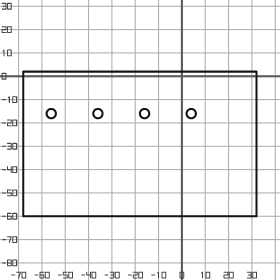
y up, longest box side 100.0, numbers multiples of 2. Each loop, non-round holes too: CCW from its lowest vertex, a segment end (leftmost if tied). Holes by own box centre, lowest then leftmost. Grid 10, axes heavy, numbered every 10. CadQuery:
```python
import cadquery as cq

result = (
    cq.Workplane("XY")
    .moveTo(-68.0, -60.0)
    .lineTo(32.0, -60.0)
    .lineTo(32.0, 2.0)
    .lineTo(-68.0, 2.0)
    .close()
    .moveTo(-56.0, -16.0)
    .circle(2.0)
    .moveTo(-36.0, -16.0)
    .circle(2.0)
    .moveTo(-16.0, -16.0)
    .circle(2.0)
    .moveTo(4.0, -16.0)
    .circle(2.0)
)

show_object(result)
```